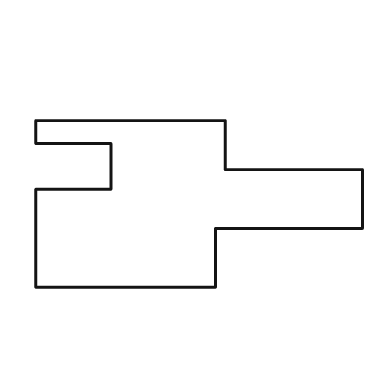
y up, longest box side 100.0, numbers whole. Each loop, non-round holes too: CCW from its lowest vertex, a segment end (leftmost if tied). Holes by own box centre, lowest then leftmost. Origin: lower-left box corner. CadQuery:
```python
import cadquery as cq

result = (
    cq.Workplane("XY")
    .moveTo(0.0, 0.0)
    .lineTo(55.0, 0.0)
    .lineTo(55.0, 18.0)
    .lineTo(100.0, 18.0)
    .lineTo(100.0, 36.0)
    .lineTo(58.0, 36.0)
    .lineTo(58.0, 51.0)
    .lineTo(0.0, 51.0)
    .lineTo(0.0, 44.0)
    .lineTo(23.0, 44.0)
    .lineTo(23.0, 30.0)
    .lineTo(0.0, 30.0)
    .close()
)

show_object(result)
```